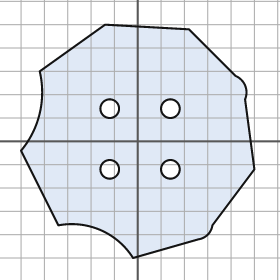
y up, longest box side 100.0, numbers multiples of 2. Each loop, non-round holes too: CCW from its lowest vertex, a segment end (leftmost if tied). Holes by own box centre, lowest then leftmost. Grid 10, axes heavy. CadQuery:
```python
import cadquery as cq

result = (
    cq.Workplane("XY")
    .moveTo(-2.0, -50.0)
    .lineTo(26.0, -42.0)
    .threePointArc((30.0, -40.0), (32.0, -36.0))
    .lineTo(50.0, -12.0)
    .lineTo(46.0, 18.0)
    .threePointArc((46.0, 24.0), (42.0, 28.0))
    .lineTo(22.0, 48.0)
    .lineTo(-14.0, 50.0)
    .lineTo(-42.0, 30.0)
    .threePointArc((-42.0, 12.0), (-50.0, -4.0))
    .lineTo(-34.0, -36.0)
    .threePointArc((-16.0, -38.0), (-2.0, -50.0))
    .close()
    .moveTo(-12.0, -12.0)
    .circle(4.0)
    .moveTo(14.0, -12.0)
    .circle(4.0)
    .moveTo(-12.0, 14.0)
    .circle(4.0)
    .moveTo(14.0, 14.0)
    .circle(4.0)
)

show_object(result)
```